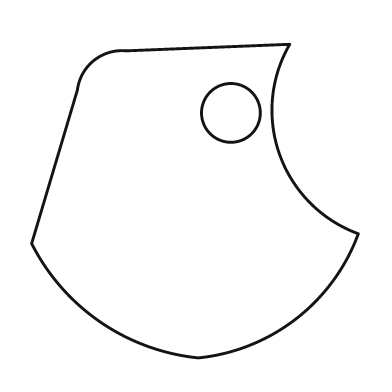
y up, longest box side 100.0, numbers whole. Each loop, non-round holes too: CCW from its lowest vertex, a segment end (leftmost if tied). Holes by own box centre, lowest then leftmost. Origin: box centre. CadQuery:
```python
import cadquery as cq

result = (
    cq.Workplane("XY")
    .moveTo(1.0, -48.0)
    .threePointArc((31.0, -36.0), (50.0, -10.0))
    .threePointArc((26.0, 14.0), (29.0, 48.0))
    .lineTo(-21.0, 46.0)
    .threePointArc((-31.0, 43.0), (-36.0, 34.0))
    .lineTo(-50.0, -13.0)
    .threePointArc((-29.0, -37.0), (1.0, -48.0))
    .close()
    .moveTo(11.0, 27.0)
    .circle(9.0)
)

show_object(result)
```